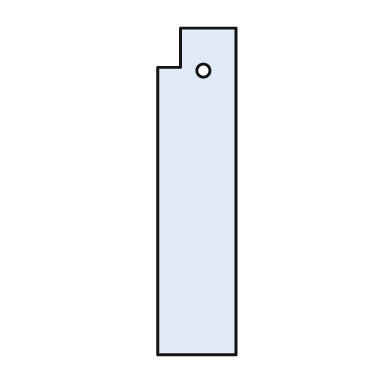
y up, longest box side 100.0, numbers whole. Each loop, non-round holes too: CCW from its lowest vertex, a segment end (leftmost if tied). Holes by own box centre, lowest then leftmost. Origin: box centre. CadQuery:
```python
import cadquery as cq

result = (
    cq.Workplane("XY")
    .moveTo(-12.0, -50.0)
    .lineTo(12.0, -50.0)
    .lineTo(12.0, 50.0)
    .lineTo(-5.0, 50.0)
    .lineTo(-5.0, 38.0)
    .lineTo(-12.0, 38.0)
    .close()
    .moveTo(2.0, 37.0)
    .circle(2.0)
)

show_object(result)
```